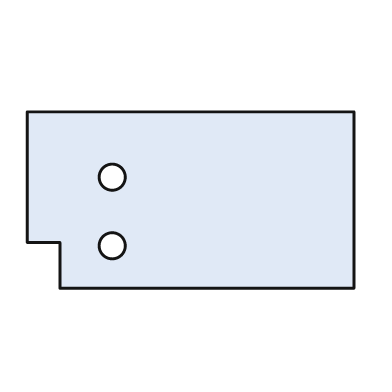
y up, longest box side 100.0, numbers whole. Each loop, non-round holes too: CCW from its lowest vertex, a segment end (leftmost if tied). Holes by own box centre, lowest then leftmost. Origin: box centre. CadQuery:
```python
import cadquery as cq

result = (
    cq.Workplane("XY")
    .moveTo(-40.0, -27.0)
    .lineTo(50.0, -27.0)
    .lineTo(50.0, 27.0)
    .lineTo(-50.0, 27.0)
    .lineTo(-50.0, -13.0)
    .lineTo(-40.0, -13.0)
    .close()
    .moveTo(-24.0, -14.0)
    .circle(4.0)
    .moveTo(-24.0, 7.0)
    .circle(4.0)
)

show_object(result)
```